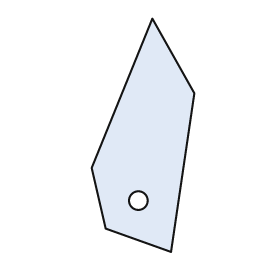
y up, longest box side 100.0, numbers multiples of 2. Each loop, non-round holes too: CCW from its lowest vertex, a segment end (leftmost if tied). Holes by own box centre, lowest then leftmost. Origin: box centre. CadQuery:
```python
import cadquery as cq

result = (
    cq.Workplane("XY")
    .moveTo(12.0, -50.0)
    .lineTo(22.0, 18.0)
    .lineTo(4.0, 50.0)
    .lineTo(-22.0, -14.0)
    .lineTo(-16.0, -40.0)
    .close()
    .moveTo(-2.0, -28.0)
    .circle(4.0)
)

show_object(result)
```